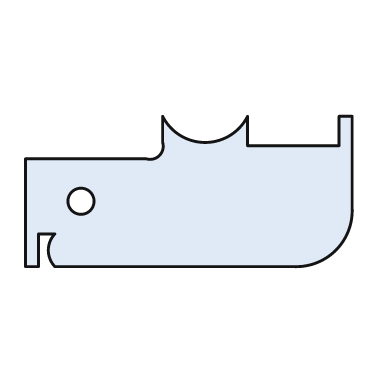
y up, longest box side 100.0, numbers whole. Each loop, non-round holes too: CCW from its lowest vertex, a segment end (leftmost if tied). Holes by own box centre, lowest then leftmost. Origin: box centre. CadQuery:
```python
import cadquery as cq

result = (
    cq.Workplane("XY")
    .moveTo(-50.0, -23.0)
    .lineTo(-46.0, -23.0)
    .lineTo(-46.0, -13.0)
    .lineTo(-41.0, -13.0)
    .threePointArc((-43.0, -18.0), (-41.0, -23.0))
    .lineTo(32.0, -23.0)
    .threePointArc((45.0, -18.0), (50.0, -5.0))
    .lineTo(50.0, 23.0)
    .lineTo(46.0, 23.0)
    .lineTo(46.0, 14.0)
    .lineTo(18.0, 14.0)
    .lineTo(18.0, 23.0)
    .threePointArc((5.0, 15.0), (-8.0, 23.0))
    .lineTo(-8.0, 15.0)
    .threePointArc((-9.0, 11.0), (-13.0, 10.0))
    .lineTo(-50.0, 10.0)
    .close()
    .moveTo(-33.0, -3.0)
    .circle(4.0)
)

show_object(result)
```